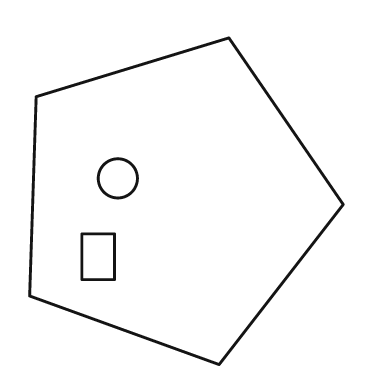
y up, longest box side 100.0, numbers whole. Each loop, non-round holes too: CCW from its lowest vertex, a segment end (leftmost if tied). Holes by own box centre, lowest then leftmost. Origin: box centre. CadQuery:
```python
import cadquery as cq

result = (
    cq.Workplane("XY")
    .moveTo(10.0, -50.0)
    .lineTo(48.0, -1.0)
    .lineTo(13.0, 50.0)
    .lineTo(-46.0, 32.0)
    .lineTo(-48.0, -29.0)
    .close()
    .moveTo(-32.0, -24.0)
    .lineTo(-22.0, -24.0)
    .lineTo(-22.0, -10.0)
    .lineTo(-32.0, -10.0)
    .close()
    .moveTo(-21.0, 7.0)
    .circle(6.0)
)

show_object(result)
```